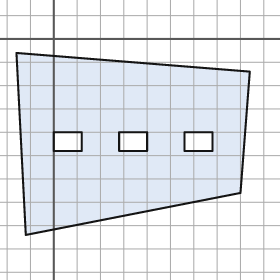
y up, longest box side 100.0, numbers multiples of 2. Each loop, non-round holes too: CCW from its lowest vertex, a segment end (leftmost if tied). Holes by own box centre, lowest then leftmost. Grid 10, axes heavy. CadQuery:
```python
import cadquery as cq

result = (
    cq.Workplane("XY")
    .moveTo(-12.0, -84.0)
    .lineTo(80.0, -66.0)
    .lineTo(84.0, -14.0)
    .lineTo(-16.0, -6.0)
    .close()
    .moveTo(0.0, -48.0)
    .lineTo(12.0, -48.0)
    .lineTo(12.0, -40.0)
    .lineTo(0.0, -40.0)
    .close()
    .moveTo(28.0, -48.0)
    .lineTo(40.0, -48.0)
    .lineTo(40.0, -40.0)
    .lineTo(28.0, -40.0)
    .close()
    .moveTo(56.0, -48.0)
    .lineTo(68.0, -48.0)
    .lineTo(68.0, -40.0)
    .lineTo(56.0, -40.0)
    .close()
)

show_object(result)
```